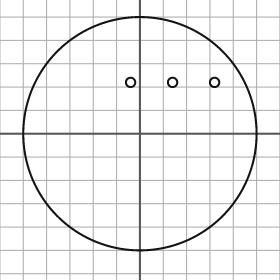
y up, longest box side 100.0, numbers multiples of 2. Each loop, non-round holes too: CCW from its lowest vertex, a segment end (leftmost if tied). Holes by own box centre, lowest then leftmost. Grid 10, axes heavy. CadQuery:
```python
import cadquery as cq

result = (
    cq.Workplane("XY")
    .moveTo(0.0, 0.0)
    .circle(50.0)
    .moveTo(-4.0, 22.0)
    .circle(2.0)
    .moveTo(14.0, 22.0)
    .circle(2.0)
    .moveTo(32.0, 22.0)
    .circle(2.0)
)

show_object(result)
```